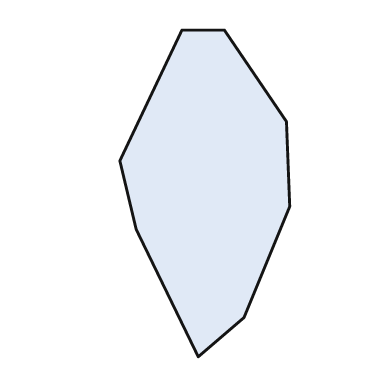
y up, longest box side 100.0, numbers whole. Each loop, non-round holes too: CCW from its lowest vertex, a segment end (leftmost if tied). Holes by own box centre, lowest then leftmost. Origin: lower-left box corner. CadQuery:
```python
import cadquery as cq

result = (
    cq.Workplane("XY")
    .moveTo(24.0, 0.0)
    .lineTo(38.0, 12.0)
    .lineTo(52.0, 46.0)
    .lineTo(51.0, 72.0)
    .lineTo(32.0, 100.0)
    .lineTo(19.0, 100.0)
    .lineTo(0.0, 60.0)
    .lineTo(5.0, 39.0)
    .close()
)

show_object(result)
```